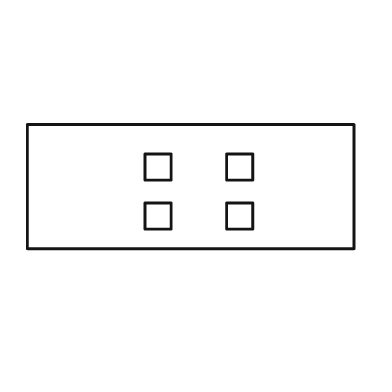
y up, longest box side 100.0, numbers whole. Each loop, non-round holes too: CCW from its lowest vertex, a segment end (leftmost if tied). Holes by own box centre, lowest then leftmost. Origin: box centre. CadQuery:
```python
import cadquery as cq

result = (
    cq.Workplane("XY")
    .moveTo(-50.0, -19.0)
    .lineTo(50.0, -19.0)
    .lineTo(50.0, 19.0)
    .lineTo(-50.0, 19.0)
    .close()
    .moveTo(-14.0, -13.0)
    .lineTo(-6.0, -13.0)
    .lineTo(-6.0, -5.0)
    .lineTo(-14.0, -5.0)
    .close()
    .moveTo(11.0, -13.0)
    .lineTo(19.0, -13.0)
    .lineTo(19.0, -5.0)
    .lineTo(11.0, -5.0)
    .close()
    .moveTo(-14.0, 2.0)
    .lineTo(-6.0, 2.0)
    .lineTo(-6.0, 10.0)
    .lineTo(-14.0, 10.0)
    .close()
    .moveTo(11.0, 2.0)
    .lineTo(19.0, 2.0)
    .lineTo(19.0, 10.0)
    .lineTo(11.0, 10.0)
    .close()
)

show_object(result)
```